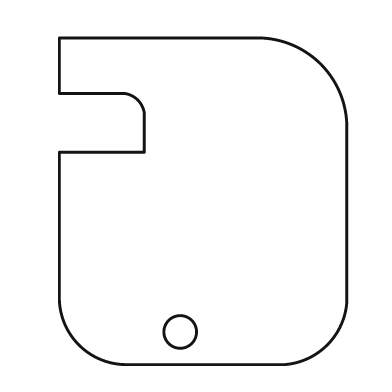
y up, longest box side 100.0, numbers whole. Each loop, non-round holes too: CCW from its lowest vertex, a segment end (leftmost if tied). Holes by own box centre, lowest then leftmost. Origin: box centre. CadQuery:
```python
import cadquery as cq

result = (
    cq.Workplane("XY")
    .moveTo(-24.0, -50.0)
    .lineTo(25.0, -50.0)
    .threePointArc((38.0, -44.0), (44.0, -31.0))
    .lineTo(44.0, 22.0)
    .threePointArc((36.0, 42.0), (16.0, 50.0))
    .lineTo(-44.0, 50.0)
    .lineTo(-44.0, 33.0)
    .lineTo(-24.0, 33.0)
    .threePointArc((-20.0, 31.0), (-18.0, 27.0))
    .lineTo(-18.0, 15.0)
    .lineTo(-44.0, 15.0)
    .lineTo(-44.0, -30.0)
    .threePointArc((-38.0, -44.0), (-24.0, -50.0))
    .close()
    .moveTo(-7.0, -40.0)
    .circle(5.0)
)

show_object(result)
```